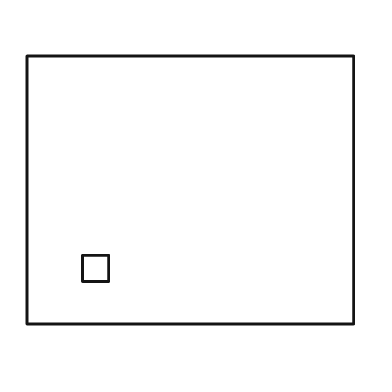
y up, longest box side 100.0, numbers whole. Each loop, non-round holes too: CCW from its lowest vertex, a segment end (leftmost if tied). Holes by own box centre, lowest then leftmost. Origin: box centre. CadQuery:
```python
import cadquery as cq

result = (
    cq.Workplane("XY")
    .moveTo(-50.0, -41.0)
    .lineTo(50.0, -41.0)
    .lineTo(50.0, 41.0)
    .lineTo(-50.0, 41.0)
    .close()
    .moveTo(-33.0, -28.0)
    .lineTo(-25.0, -28.0)
    .lineTo(-25.0, -20.0)
    .lineTo(-33.0, -20.0)
    .close()
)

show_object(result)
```